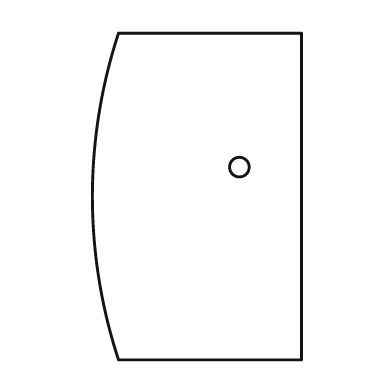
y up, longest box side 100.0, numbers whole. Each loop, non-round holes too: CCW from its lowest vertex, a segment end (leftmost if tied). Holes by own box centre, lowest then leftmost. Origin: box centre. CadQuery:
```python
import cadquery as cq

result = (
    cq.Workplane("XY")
    .moveTo(-24.0, -50.0)
    .lineTo(32.0, -50.0)
    .lineTo(32.0, 50.0)
    .lineTo(-24.0, 50.0)
    .threePointArc((-32.0, 0.0), (-24.0, -50.0))
    .close()
    .moveTo(13.0, 9.0)
    .circle(3.0)
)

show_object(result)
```